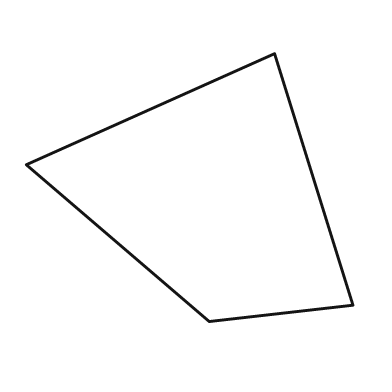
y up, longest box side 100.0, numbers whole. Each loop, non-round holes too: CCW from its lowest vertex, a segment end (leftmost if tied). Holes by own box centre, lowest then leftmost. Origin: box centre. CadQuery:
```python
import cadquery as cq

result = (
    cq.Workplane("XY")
    .moveTo(6.0, -41.0)
    .lineTo(50.0, -36.0)
    .lineTo(26.0, 41.0)
    .lineTo(-50.0, 7.0)
    .close()
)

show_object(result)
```